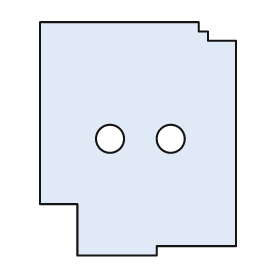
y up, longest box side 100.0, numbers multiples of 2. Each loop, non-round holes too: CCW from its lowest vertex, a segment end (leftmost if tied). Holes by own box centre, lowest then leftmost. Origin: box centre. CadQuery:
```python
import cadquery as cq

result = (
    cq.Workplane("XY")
    .moveTo(-26.0, -50.0)
    .lineTo(8.0, -50.0)
    .lineTo(8.0, -46.0)
    .lineTo(42.0, -46.0)
    .lineTo(42.0, 42.0)
    .lineTo(30.0, 42.0)
    .lineTo(30.0, 46.0)
    .lineTo(26.0, 46.0)
    .lineTo(26.0, 50.0)
    .lineTo(-42.0, 50.0)
    .lineTo(-42.0, -28.0)
    .lineTo(-26.0, -28.0)
    .close()
    .moveTo(-12.0, 0.0)
    .circle(6.0)
    .moveTo(14.0, 0.0)
    .circle(6.0)
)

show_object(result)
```